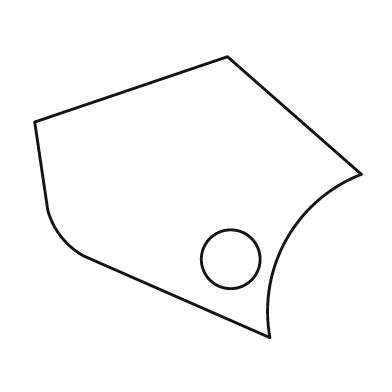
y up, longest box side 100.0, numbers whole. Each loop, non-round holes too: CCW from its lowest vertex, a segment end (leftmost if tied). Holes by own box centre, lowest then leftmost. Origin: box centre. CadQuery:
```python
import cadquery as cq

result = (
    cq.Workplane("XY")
    .moveTo(22.0, -43.0)
    .threePointArc((27.0, -13.0), (50.0, 7.0))
    .lineTo(9.0, 43.0)
    .lineTo(-50.0, 23.0)
    .lineTo(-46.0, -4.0)
    .threePointArc((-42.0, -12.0), (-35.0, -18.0))
    .close()
    .moveTo(10.0, -19.0)
    .circle(9.0)
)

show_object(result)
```